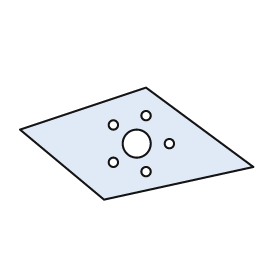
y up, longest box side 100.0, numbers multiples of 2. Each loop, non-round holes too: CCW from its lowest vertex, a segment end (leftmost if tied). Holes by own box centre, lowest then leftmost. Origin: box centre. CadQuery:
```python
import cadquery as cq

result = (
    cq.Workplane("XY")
    .moveTo(-14.0, -24.0)
    .lineTo(50.0, -10.0)
    .lineTo(4.0, 24.0)
    .lineTo(-50.0, 6.0)
    .close()
    .moveTo(4.0, -12.0)
    .circle(2.0)
    .moveTo(-10.0, -8.0)
    .circle(2.0)
    .moveTo(0.0, 0.0)
    .circle(6.0)
    .moveTo(14.0, 0.0)
    .circle(2.0)
    .moveTo(-10.0, 8.0)
    .circle(2.0)
    .moveTo(4.0, 12.0)
    .circle(2.0)
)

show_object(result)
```